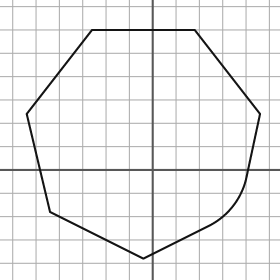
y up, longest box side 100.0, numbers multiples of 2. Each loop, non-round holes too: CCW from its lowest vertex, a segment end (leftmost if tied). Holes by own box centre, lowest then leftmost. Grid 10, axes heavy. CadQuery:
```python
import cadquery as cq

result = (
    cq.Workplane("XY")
    .moveTo(-4.0, -38.0)
    .lineTo(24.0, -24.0)
    .threePointArc((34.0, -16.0), (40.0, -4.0))
    .lineTo(46.0, 24.0)
    .lineTo(18.0, 60.0)
    .lineTo(-26.0, 60.0)
    .lineTo(-54.0, 24.0)
    .lineTo(-44.0, -18.0)
    .close()
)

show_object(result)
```